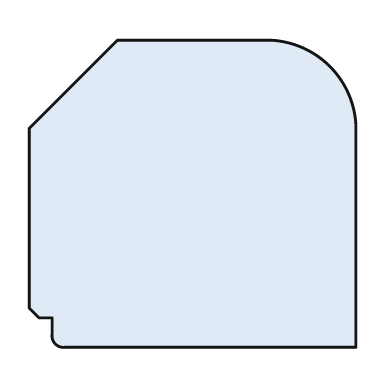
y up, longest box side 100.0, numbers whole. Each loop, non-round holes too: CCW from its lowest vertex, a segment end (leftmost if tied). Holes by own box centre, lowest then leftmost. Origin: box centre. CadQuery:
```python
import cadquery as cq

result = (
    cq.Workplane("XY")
    .moveTo(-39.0, -47.0)
    .lineTo(50.0, -47.0)
    .lineTo(50.0, 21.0)
    .threePointArc((42.0, 39.0), (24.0, 47.0))
    .lineTo(-23.0, 47.0)
    .lineTo(-50.0, 20.0)
    .lineTo(-50.0, -35.0)
    .lineTo(-47.0, -38.0)
    .lineTo(-43.0, -38.0)
    .lineTo(-43.0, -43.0)
    .threePointArc((-42.0, -46.0), (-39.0, -47.0))
    .close()
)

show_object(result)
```